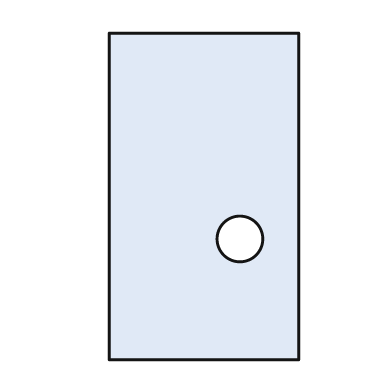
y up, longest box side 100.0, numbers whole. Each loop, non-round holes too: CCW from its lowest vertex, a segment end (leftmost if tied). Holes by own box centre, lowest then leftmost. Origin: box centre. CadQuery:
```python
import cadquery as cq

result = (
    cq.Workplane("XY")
    .moveTo(-29.0, -50.0)
    .lineTo(29.0, -50.0)
    .lineTo(29.0, 50.0)
    .lineTo(-29.0, 50.0)
    .close()
    .moveTo(11.0, -13.0)
    .circle(7.0)
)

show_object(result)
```